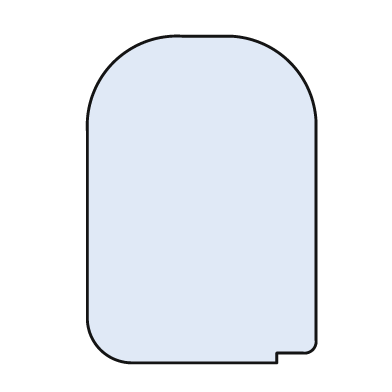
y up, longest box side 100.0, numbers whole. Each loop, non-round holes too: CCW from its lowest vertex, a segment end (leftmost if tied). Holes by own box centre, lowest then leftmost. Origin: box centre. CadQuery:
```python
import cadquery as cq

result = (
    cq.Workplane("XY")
    .moveTo(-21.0, -50.0)
    .lineTo(23.0, -50.0)
    .lineTo(23.0, -47.0)
    .lineTo(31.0, -47.0)
    .threePointArc((34.0, -46.0), (35.0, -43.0))
    .lineTo(35.0, 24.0)
    .threePointArc((27.0, 42.0), (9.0, 50.0))
    .lineTo(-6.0, 50.0)
    .threePointArc((-27.0, 42.0), (-35.0, 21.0))
    .lineTo(-35.0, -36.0)
    .threePointArc((-31.0, -46.0), (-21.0, -50.0))
    .close()
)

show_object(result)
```